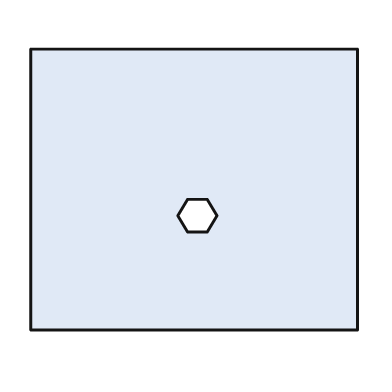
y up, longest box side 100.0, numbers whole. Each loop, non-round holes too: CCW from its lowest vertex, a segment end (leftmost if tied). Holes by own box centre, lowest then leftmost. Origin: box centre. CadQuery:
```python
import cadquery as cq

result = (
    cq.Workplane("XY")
    .moveTo(-50.0, -43.0)
    .lineTo(50.0, -43.0)
    .lineTo(50.0, 43.0)
    .lineTo(-50.0, 43.0)
    .close()
    .moveTo(-2.0, -13.0)
    .lineTo(4.0, -13.0)
    .lineTo(7.0, -8.0)
    .lineTo(4.0, -3.0)
    .lineTo(-2.0, -3.0)
    .lineTo(-5.0, -8.0)
    .close()
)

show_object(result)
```